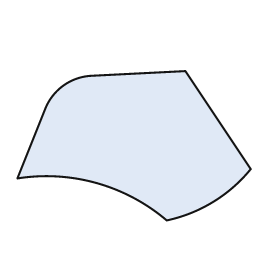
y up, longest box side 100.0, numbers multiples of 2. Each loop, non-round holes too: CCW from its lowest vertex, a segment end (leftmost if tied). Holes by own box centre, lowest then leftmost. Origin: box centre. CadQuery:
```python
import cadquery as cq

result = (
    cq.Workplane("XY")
    .moveTo(14.0, -32.0)
    .threePointArc((34.0, -24.0), (50.0, -10.0))
    .lineTo(22.0, 32.0)
    .lineTo(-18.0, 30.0)
    .threePointArc((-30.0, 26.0), (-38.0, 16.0))
    .lineTo(-50.0, -14.0)
    .threePointArc((-16.0, -16.0), (14.0, -32.0))
    .close()
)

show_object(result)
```